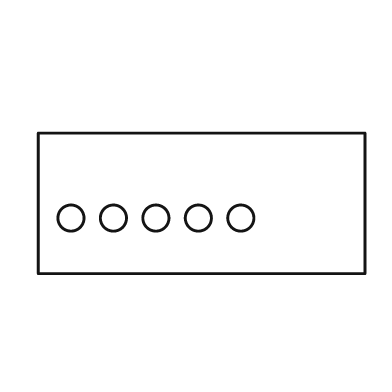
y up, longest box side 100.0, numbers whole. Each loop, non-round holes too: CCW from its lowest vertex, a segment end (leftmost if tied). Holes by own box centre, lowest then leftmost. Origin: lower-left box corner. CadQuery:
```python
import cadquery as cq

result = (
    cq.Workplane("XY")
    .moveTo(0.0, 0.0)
    .lineTo(100.0, 0.0)
    .lineTo(100.0, 43.0)
    .lineTo(0.0, 43.0)
    .close()
    .moveTo(10.0, 17.0)
    .circle(4.0)
    .moveTo(23.0, 17.0)
    .circle(4.0)
    .moveTo(36.0, 17.0)
    .circle(4.0)
    .moveTo(49.0, 17.0)
    .circle(4.0)
    .moveTo(62.0, 17.0)
    .circle(4.0)
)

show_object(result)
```